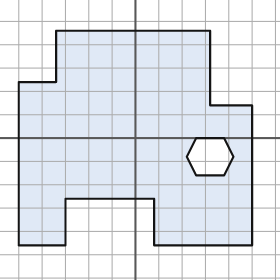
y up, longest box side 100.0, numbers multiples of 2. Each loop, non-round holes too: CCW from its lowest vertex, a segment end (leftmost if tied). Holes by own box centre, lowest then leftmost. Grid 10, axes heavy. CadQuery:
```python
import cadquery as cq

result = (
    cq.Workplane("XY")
    .moveTo(-50.0, -46.0)
    .lineTo(-30.0, -46.0)
    .lineTo(-30.0, -26.0)
    .lineTo(8.0, -26.0)
    .lineTo(8.0, -46.0)
    .lineTo(50.0, -46.0)
    .lineTo(50.0, 14.0)
    .lineTo(32.0, 14.0)
    .lineTo(32.0, 46.0)
    .lineTo(-34.0, 46.0)
    .lineTo(-34.0, 24.0)
    .lineTo(-50.0, 24.0)
    .close()
    .moveTo(26.0, -16.0)
    .lineTo(38.0, -16.0)
    .lineTo(42.0, -8.0)
    .lineTo(38.0, 0.0)
    .lineTo(26.0, 0.0)
    .lineTo(22.0, -8.0)
    .close()
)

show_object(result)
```